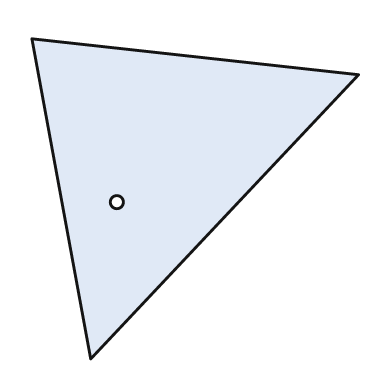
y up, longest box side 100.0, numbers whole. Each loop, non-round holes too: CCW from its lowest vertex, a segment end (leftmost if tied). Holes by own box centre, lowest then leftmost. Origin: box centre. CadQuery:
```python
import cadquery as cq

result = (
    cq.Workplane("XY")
    .moveTo(-32.0, -49.0)
    .lineTo(50.0, 38.0)
    .lineTo(-50.0, 49.0)
    .close()
    .moveTo(-24.0, -1.0)
    .circle(2.0)
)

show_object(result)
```